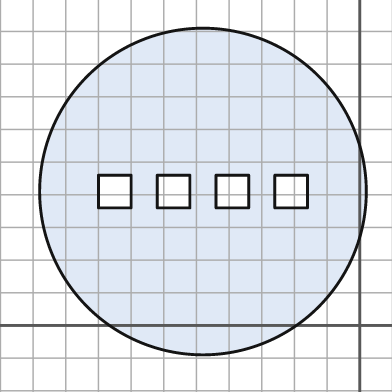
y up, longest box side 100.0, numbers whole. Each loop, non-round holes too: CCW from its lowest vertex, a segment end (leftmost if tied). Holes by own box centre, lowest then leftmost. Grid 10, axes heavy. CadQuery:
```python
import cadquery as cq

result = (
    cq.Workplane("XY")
    .moveTo(-48.0, 41.0)
    .circle(50.0)
    .moveTo(-80.0, 36.0)
    .lineTo(-70.0, 36.0)
    .lineTo(-70.0, 46.0)
    .lineTo(-80.0, 46.0)
    .close()
    .moveTo(-62.0, 36.0)
    .lineTo(-52.0, 36.0)
    .lineTo(-52.0, 46.0)
    .lineTo(-62.0, 46.0)
    .close()
    .moveTo(-44.0, 36.0)
    .lineTo(-34.0, 36.0)
    .lineTo(-34.0, 46.0)
    .lineTo(-44.0, 46.0)
    .close()
    .moveTo(-26.0, 36.0)
    .lineTo(-16.0, 36.0)
    .lineTo(-16.0, 46.0)
    .lineTo(-26.0, 46.0)
    .close()
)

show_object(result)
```